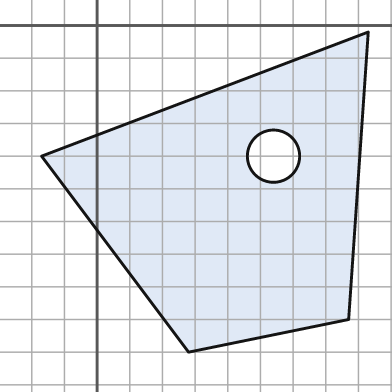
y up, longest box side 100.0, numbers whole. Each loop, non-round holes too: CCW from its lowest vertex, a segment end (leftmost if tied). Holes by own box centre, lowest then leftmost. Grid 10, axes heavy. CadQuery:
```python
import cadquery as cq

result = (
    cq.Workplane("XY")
    .moveTo(28.0, -100.0)
    .lineTo(77.0, -90.0)
    .lineTo(83.0, -2.0)
    .lineTo(-17.0, -40.0)
    .close()
    .moveTo(54.0, -40.0)
    .circle(8.0)
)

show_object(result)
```